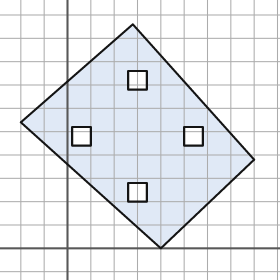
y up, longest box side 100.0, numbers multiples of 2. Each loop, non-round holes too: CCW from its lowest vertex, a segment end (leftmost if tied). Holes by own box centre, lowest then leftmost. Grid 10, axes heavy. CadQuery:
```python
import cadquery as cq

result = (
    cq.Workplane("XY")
    .moveTo(40.0, 0.0)
    .lineTo(80.0, 38.0)
    .lineTo(28.0, 96.0)
    .lineTo(-20.0, 54.0)
    .close()
    .moveTo(26.0, 20.0)
    .lineTo(34.0, 20.0)
    .lineTo(34.0, 28.0)
    .lineTo(26.0, 28.0)
    .close()
    .moveTo(2.0, 44.0)
    .lineTo(10.0, 44.0)
    .lineTo(10.0, 52.0)
    .lineTo(2.0, 52.0)
    .close()
    .moveTo(50.0, 44.0)
    .lineTo(58.0, 44.0)
    .lineTo(58.0, 52.0)
    .lineTo(50.0, 52.0)
    .close()
    .moveTo(26.0, 68.0)
    .lineTo(34.0, 68.0)
    .lineTo(34.0, 76.0)
    .lineTo(26.0, 76.0)
    .close()
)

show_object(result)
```